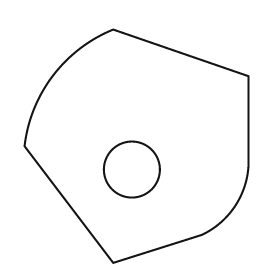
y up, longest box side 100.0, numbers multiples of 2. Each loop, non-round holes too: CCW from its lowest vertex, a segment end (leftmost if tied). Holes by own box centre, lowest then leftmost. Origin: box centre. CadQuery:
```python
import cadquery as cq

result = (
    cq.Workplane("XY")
    .moveTo(-10.0, -50.0)
    .lineTo(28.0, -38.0)
    .threePointArc((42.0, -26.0), (48.0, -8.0))
    .lineTo(48.0, 30.0)
    .lineTo(-10.0, 50.0)
    .threePointArc((-36.0, 30.0), (-48.0, 0.0))
    .close()
    .moveTo(-2.0, -10.0)
    .circle(12.0)
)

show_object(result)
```